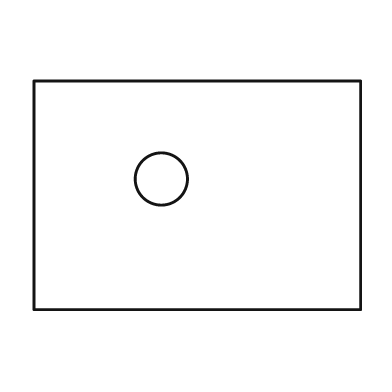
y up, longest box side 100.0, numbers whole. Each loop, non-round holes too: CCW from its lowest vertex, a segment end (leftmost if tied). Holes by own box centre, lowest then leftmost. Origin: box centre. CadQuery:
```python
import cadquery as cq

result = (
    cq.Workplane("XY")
    .moveTo(-50.0, -35.0)
    .lineTo(50.0, -35.0)
    .lineTo(50.0, 35.0)
    .lineTo(-50.0, 35.0)
    .close()
    .moveTo(-11.0, 5.0)
    .circle(8.0)
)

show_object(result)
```